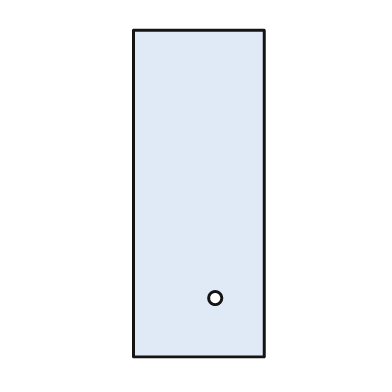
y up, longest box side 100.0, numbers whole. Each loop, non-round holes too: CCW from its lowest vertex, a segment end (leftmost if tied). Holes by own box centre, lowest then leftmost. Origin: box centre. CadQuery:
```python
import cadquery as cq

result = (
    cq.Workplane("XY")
    .moveTo(-20.0, -50.0)
    .lineTo(20.0, -50.0)
    .lineTo(20.0, 50.0)
    .lineTo(-20.0, 50.0)
    .close()
    .moveTo(5.0, -32.0)
    .circle(2.0)
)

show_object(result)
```